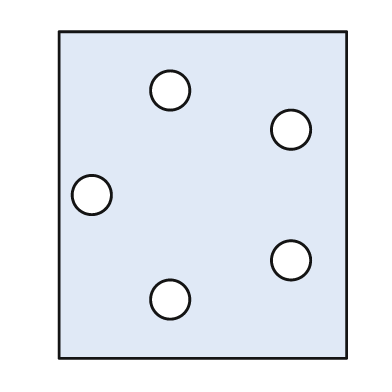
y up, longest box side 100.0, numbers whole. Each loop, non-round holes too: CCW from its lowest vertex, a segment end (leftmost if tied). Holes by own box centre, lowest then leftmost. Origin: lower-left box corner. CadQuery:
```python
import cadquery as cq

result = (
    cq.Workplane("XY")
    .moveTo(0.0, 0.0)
    .lineTo(88.0, 0.0)
    .lineTo(88.0, 100.0)
    .lineTo(0.0, 100.0)
    .close()
    .moveTo(34.0, 18.0)
    .circle(6.0)
    .moveTo(71.0, 30.0)
    .circle(6.0)
    .moveTo(10.0, 50.0)
    .circle(6.0)
    .moveTo(71.0, 70.0)
    .circle(6.0)
    .moveTo(34.0, 82.0)
    .circle(6.0)
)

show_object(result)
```